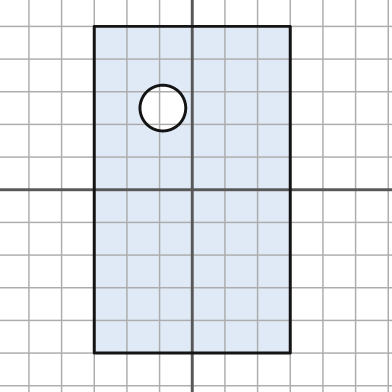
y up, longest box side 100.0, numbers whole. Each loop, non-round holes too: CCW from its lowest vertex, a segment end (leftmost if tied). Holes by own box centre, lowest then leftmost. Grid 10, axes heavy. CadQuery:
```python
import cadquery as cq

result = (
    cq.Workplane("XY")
    .moveTo(-30.0, -50.0)
    .lineTo(30.0, -50.0)
    .lineTo(30.0, 50.0)
    .lineTo(-30.0, 50.0)
    .close()
    .moveTo(-9.0, 25.0)
    .circle(7.0)
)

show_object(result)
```